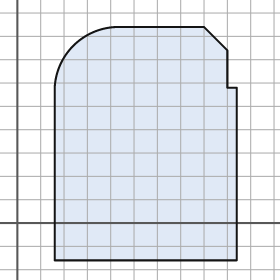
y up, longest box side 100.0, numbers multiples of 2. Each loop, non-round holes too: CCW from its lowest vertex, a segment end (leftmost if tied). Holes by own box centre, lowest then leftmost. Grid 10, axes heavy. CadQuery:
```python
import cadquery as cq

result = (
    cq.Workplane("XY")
    .moveTo(16.0, -16.0)
    .lineTo(94.0, -16.0)
    .lineTo(94.0, 58.0)
    .lineTo(90.0, 58.0)
    .lineTo(90.0, 74.0)
    .lineTo(80.0, 84.0)
    .lineTo(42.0, 84.0)
    .threePointArc((24.0, 76.0), (16.0, 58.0))
    .close()
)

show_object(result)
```